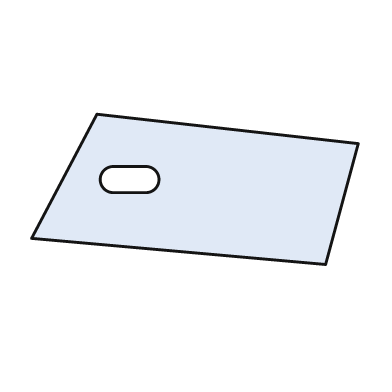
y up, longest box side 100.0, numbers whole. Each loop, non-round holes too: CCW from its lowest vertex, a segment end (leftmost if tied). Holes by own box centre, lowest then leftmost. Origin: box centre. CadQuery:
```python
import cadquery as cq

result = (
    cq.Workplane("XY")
    .moveTo(40.0, -23.0)
    .lineTo(50.0, 14.0)
    .lineTo(-30.0, 23.0)
    .lineTo(-50.0, -15.0)
    .close()
    .moveTo(-25.0, -1.0)
    .lineTo(-15.0, -1.0)
    .threePointArc((-11.0, 3.0), (-15.0, 7.0))
    .lineTo(-25.0, 7.0)
    .threePointArc((-29.0, 3.0), (-25.0, -1.0))
    .close()
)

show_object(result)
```